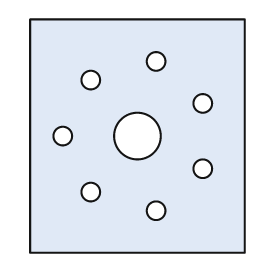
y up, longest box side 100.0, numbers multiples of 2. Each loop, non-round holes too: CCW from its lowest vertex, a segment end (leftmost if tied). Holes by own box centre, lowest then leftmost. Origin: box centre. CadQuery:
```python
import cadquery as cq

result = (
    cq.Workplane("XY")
    .moveTo(-46.0, -50.0)
    .lineTo(46.0, -50.0)
    .lineTo(46.0, 50.0)
    .lineTo(-46.0, 50.0)
    .close()
    .moveTo(8.0, -32.0)
    .circle(4.0)
    .moveTo(-20.0, -24.0)
    .circle(4.0)
    .moveTo(28.0, -14.0)
    .circle(4.0)
    .moveTo(-32.0, 0.0)
    .circle(4.0)
    .moveTo(0.0, 0.0)
    .circle(10.0)
    .moveTo(28.0, 14.0)
    .circle(4.0)
    .moveTo(-20.0, 24.0)
    .circle(4.0)
    .moveTo(8.0, 32.0)
    .circle(4.0)
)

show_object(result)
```